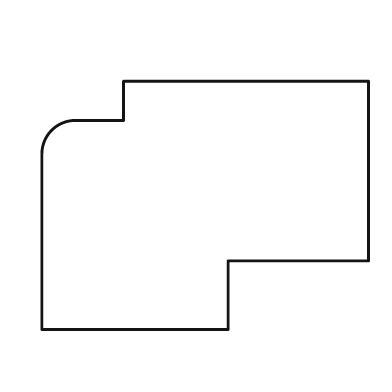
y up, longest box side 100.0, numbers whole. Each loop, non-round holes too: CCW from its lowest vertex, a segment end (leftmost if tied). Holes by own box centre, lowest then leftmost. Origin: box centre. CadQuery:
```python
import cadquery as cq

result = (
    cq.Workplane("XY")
    .moveTo(-50.0, -38.0)
    .lineTo(7.0, -38.0)
    .lineTo(7.0, -17.0)
    .lineTo(50.0, -17.0)
    .lineTo(50.0, 38.0)
    .lineTo(-25.0, 38.0)
    .lineTo(-25.0, 26.0)
    .lineTo(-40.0, 26.0)
    .threePointArc((-47.0, 23.0), (-50.0, 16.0))
    .close()
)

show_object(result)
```